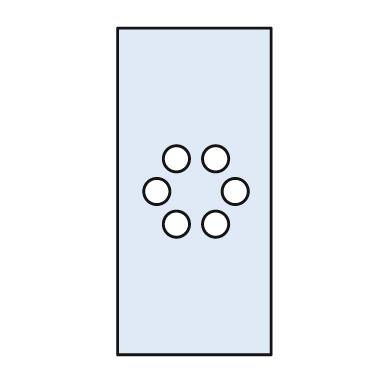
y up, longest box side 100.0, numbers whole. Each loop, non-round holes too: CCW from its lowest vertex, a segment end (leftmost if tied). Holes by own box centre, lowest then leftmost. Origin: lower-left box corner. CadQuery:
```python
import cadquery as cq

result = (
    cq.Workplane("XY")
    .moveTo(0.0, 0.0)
    .lineTo(47.0, 0.0)
    .lineTo(47.0, 100.0)
    .lineTo(0.0, 100.0)
    .close()
    .moveTo(18.0, 40.0)
    .circle(4.0)
    .moveTo(30.0, 40.0)
    .circle(4.0)
    .moveTo(12.0, 50.0)
    .circle(4.0)
    .moveTo(36.0, 50.0)
    .circle(4.0)
    .moveTo(18.0, 60.0)
    .circle(4.0)
    .moveTo(30.0, 60.0)
    .circle(4.0)
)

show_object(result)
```